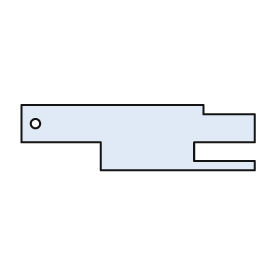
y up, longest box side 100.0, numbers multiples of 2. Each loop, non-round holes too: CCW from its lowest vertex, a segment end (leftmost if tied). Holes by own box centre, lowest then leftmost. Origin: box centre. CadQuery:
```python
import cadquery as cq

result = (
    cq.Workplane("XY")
    .moveTo(-16.0, -14.0)
    .lineTo(50.0, -14.0)
    .lineTo(50.0, -10.0)
    .lineTo(24.0, -10.0)
    .lineTo(24.0, -2.0)
    .lineTo(50.0, -2.0)
    .lineTo(50.0, 10.0)
    .lineTo(28.0, 10.0)
    .lineTo(28.0, 14.0)
    .lineTo(-50.0, 14.0)
    .lineTo(-50.0, -2.0)
    .lineTo(-16.0, -2.0)
    .close()
    .moveTo(-44.0, 6.0)
    .circle(2.0)
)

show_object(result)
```